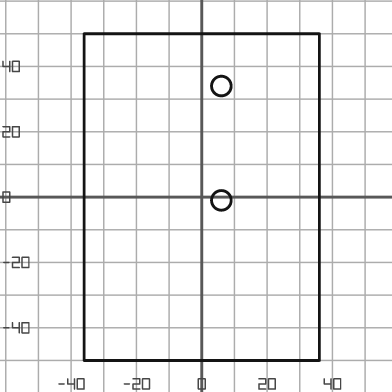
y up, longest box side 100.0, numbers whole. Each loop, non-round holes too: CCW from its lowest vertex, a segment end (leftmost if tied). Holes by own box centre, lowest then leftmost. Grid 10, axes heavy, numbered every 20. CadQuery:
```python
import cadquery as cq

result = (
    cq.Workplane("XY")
    .moveTo(-36.0, -50.0)
    .lineTo(36.0, -50.0)
    .lineTo(36.0, 50.0)
    .lineTo(-36.0, 50.0)
    .close()
    .moveTo(6.0, -1.0)
    .circle(3.0)
    .moveTo(6.0, 34.0)
    .circle(3.0)
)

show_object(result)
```